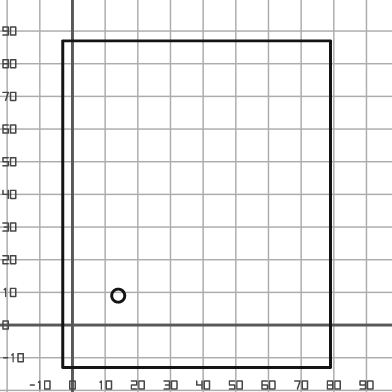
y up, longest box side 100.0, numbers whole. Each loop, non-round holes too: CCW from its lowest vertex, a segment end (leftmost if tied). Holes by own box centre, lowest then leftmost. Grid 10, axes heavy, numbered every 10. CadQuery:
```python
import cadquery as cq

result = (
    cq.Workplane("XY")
    .moveTo(-3.0, -13.0)
    .lineTo(79.0, -13.0)
    .lineTo(79.0, 87.0)
    .lineTo(-3.0, 87.0)
    .close()
    .moveTo(14.0, 9.0)
    .circle(2.0)
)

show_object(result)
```